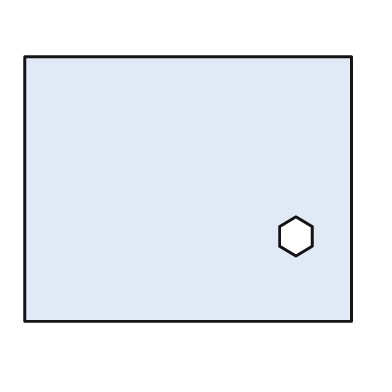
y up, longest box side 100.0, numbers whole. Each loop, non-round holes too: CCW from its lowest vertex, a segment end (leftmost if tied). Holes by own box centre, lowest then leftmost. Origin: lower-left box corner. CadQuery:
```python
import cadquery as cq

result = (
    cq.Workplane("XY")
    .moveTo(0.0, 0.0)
    .lineTo(100.0, 0.0)
    .lineTo(100.0, 81.0)
    .lineTo(0.0, 81.0)
    .close()
    .moveTo(83.0, 20.0)
    .lineTo(88.0, 23.0)
    .lineTo(88.0, 29.0)
    .lineTo(83.0, 32.0)
    .lineTo(78.0, 29.0)
    .lineTo(78.0, 23.0)
    .close()
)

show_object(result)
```